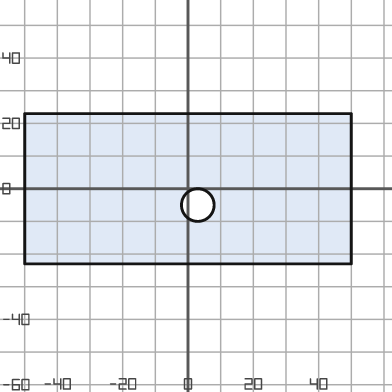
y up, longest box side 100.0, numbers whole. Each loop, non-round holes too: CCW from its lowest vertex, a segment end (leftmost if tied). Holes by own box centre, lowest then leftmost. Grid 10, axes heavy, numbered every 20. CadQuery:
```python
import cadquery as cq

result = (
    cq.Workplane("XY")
    .moveTo(-50.0, -23.0)
    .lineTo(50.0, -23.0)
    .lineTo(50.0, 23.0)
    .lineTo(-50.0, 23.0)
    .close()
    .moveTo(3.0, -5.0)
    .circle(5.0)
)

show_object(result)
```